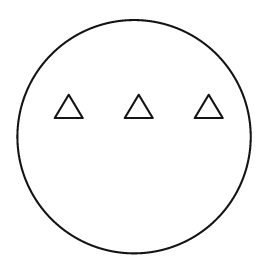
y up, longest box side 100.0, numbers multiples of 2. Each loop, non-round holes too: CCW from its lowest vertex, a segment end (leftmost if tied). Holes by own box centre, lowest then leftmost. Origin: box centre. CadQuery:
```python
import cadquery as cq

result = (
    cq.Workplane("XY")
    .moveTo(0.0, 0.0)
    .circle(50.0)
    .moveTo(-34.0, 8.0)
    .lineTo(-22.0, 8.0)
    .lineTo(-28.0, 18.0)
    .close()
    .moveTo(-4.0, 8.0)
    .lineTo(8.0, 8.0)
    .lineTo(2.0, 18.0)
    .close()
    .moveTo(26.0, 8.0)
    .lineTo(38.0, 8.0)
    .lineTo(32.0, 18.0)
    .close()
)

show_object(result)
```